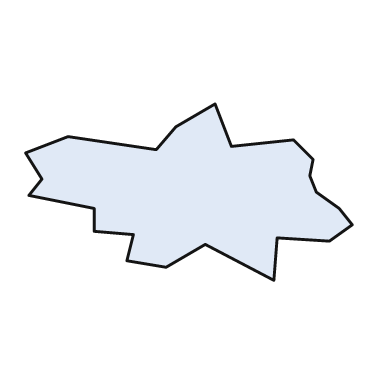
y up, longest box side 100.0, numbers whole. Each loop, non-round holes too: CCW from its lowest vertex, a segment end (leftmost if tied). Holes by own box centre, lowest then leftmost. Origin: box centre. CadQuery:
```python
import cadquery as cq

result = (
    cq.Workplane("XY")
    .moveTo(26.0, -27.0)
    .lineTo(27.0, -14.0)
    .lineTo(43.0, -15.0)
    .lineTo(50.0, -10.0)
    .lineTo(46.0, -5.0)
    .lineTo(39.0, 0.0)
    .lineTo(37.0, 5.0)
    .lineTo(38.0, 10.0)
    .lineTo(32.0, 16.0)
    .lineTo(13.0, 14.0)
    .lineTo(8.0, 27.0)
    .lineTo(-4.0, 20.0)
    .lineTo(-10.0, 13.0)
    .lineTo(-37.0, 17.0)
    .lineTo(-50.0, 12.0)
    .lineTo(-45.0, 4.0)
    .lineTo(-49.0, -1.0)
    .lineTo(-29.0, -5.0)
    .lineTo(-29.0, -12.0)
    .lineTo(-17.0, -13.0)
    .lineTo(-19.0, -21.0)
    .lineTo(-7.0, -23.0)
    .lineTo(5.0, -16.0)
    .close()
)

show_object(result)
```